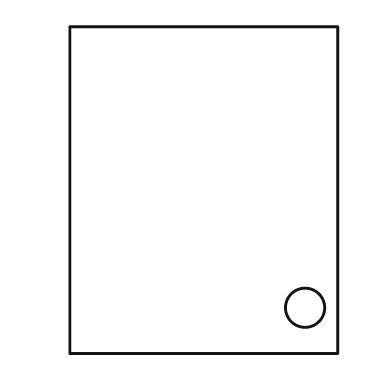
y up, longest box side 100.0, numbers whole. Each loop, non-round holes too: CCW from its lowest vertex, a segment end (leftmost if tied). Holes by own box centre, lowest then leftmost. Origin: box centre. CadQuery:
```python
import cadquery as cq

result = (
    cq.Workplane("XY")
    .moveTo(-41.0, -50.0)
    .lineTo(41.0, -50.0)
    .lineTo(41.0, 50.0)
    .lineTo(-41.0, 50.0)
    .close()
    .moveTo(31.0, -36.0)
    .circle(6.0)
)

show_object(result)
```